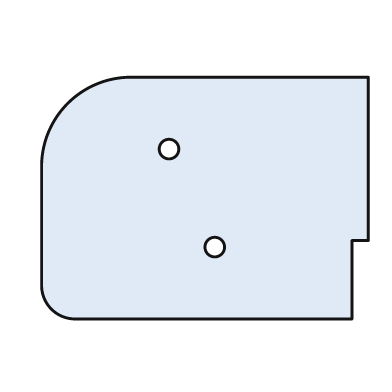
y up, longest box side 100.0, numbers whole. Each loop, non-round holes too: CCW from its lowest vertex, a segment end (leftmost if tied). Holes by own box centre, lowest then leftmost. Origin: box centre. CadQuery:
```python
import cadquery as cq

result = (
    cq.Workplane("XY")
    .moveTo(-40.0, -37.0)
    .lineTo(45.0, -37.0)
    .lineTo(45.0, -13.0)
    .lineTo(50.0, -13.0)
    .lineTo(50.0, 37.0)
    .lineTo(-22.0, 37.0)
    .threePointArc((-42.0, 29.0), (-50.0, 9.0))
    .lineTo(-50.0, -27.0)
    .threePointArc((-47.0, -34.0), (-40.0, -37.0))
    .close()
    .moveTo(3.0, -15.0)
    .circle(3.0)
    .moveTo(-11.0, 15.0)
    .circle(3.0)
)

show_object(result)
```